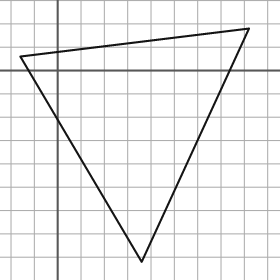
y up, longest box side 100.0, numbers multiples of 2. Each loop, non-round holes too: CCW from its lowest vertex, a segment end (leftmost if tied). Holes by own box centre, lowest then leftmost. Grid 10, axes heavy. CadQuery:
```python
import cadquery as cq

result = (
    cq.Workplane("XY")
    .moveTo(36.0, -82.0)
    .lineTo(82.0, 18.0)
    .lineTo(-16.0, 6.0)
    .close()
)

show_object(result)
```